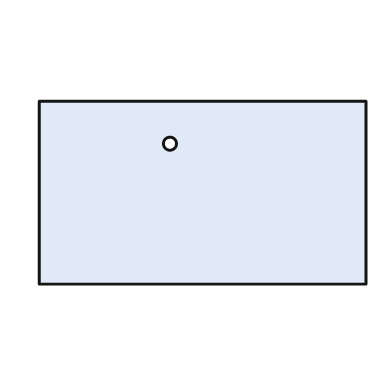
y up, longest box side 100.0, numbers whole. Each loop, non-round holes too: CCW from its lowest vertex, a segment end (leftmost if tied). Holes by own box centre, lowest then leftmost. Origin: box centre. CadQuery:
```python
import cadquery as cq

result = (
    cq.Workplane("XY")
    .moveTo(-50.0, -28.0)
    .lineTo(50.0, -28.0)
    .lineTo(50.0, 28.0)
    .lineTo(-50.0, 28.0)
    .close()
    .moveTo(-10.0, 15.0)
    .circle(2.0)
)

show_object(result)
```